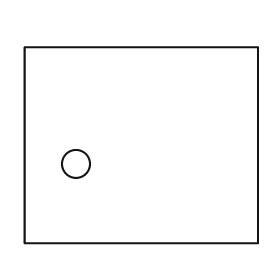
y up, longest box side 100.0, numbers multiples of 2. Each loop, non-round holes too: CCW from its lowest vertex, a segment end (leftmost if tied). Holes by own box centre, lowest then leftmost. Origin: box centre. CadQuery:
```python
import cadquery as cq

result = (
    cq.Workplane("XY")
    .moveTo(-50.0, -42.0)
    .lineTo(50.0, -42.0)
    .lineTo(50.0, 42.0)
    .lineTo(-50.0, 42.0)
    .close()
    .moveTo(-28.0, -8.0)
    .circle(6.0)
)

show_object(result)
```